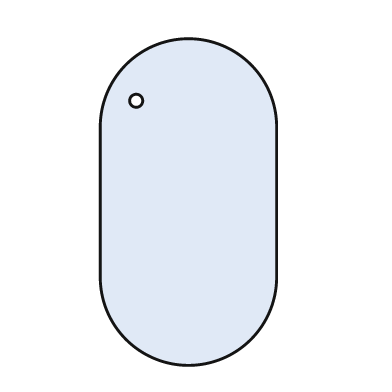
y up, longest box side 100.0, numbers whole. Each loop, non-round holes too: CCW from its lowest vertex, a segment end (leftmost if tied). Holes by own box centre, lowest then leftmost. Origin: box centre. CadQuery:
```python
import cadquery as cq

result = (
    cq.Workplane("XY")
    .moveTo(-27.0, -23.0)
    .threePointArc((0.0, -50.0), (27.0, -23.0))
    .lineTo(27.0, 23.0)
    .threePointArc((0.0, 50.0), (-27.0, 23.0))
    .close()
    .moveTo(-16.0, 31.0)
    .circle(2.0)
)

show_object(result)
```